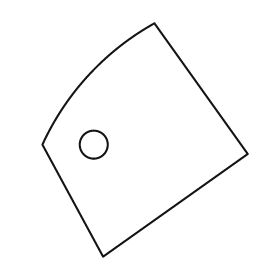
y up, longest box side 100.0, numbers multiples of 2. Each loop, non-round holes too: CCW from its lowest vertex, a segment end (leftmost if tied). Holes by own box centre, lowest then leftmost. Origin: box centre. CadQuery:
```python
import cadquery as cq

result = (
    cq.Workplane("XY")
    .moveTo(-18.0, -50.0)
    .lineTo(44.0, -6.0)
    .lineTo(4.0, 50.0)
    .threePointArc((-24.0, 28.0), (-44.0, -2.0))
    .close()
    .moveTo(-22.0, -2.0)
    .circle(6.0)
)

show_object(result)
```